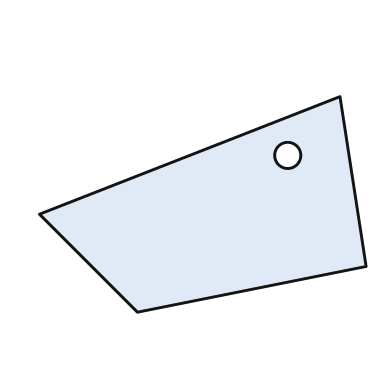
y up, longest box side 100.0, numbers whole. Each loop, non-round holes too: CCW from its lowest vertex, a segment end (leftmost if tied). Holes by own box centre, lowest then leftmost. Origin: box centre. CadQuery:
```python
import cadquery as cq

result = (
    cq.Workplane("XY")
    .moveTo(-20.0, -33.0)
    .lineTo(50.0, -19.0)
    .lineTo(42.0, 33.0)
    .lineTo(-50.0, -3.0)
    .close()
    .moveTo(26.0, 15.0)
    .circle(4.0)
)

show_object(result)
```